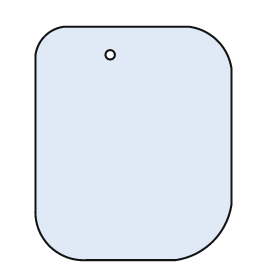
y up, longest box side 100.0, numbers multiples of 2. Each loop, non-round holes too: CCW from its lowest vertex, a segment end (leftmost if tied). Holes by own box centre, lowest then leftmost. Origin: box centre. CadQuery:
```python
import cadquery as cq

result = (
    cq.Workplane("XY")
    .moveTo(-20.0, -50.0)
    .lineTo(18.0, -50.0)
    .threePointArc((34.0, -42.0), (42.0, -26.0))
    .lineTo(42.0, 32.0)
    .threePointArc((36.0, 44.0), (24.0, 50.0))
    .lineTo(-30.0, 50.0)
    .threePointArc((-38.0, 46.0), (-42.0, 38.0))
    .lineTo(-42.0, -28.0)
    .threePointArc((-36.0, -44.0), (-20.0, -50.0))
    .close()
    .moveTo(-10.0, 38.0)
    .circle(2.0)
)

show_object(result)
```